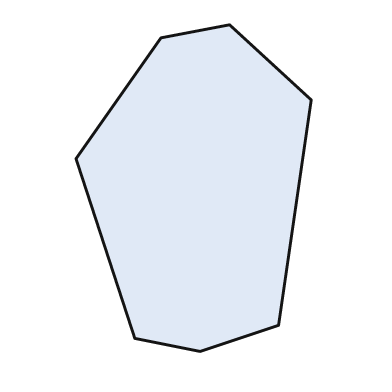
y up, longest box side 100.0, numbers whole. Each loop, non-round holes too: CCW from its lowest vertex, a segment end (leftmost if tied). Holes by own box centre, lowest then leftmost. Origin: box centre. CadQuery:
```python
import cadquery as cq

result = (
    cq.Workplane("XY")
    .moveTo(2.0, -50.0)
    .lineTo(26.0, -42.0)
    .lineTo(36.0, 27.0)
    .lineTo(11.0, 50.0)
    .lineTo(-10.0, 46.0)
    .lineTo(-36.0, 9.0)
    .lineTo(-18.0, -46.0)
    .close()
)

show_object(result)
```